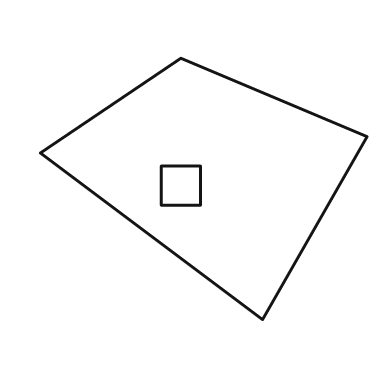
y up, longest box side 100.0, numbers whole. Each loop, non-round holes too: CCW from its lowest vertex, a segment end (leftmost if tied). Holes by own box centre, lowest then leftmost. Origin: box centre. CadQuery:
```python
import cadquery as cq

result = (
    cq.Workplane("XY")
    .moveTo(18.0, -40.0)
    .lineTo(50.0, 16.0)
    .lineTo(-7.0, 40.0)
    .lineTo(-50.0, 11.0)
    .close()
    .moveTo(-13.0, -5.0)
    .lineTo(-1.0, -5.0)
    .lineTo(-1.0, 7.0)
    .lineTo(-13.0, 7.0)
    .close()
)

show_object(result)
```